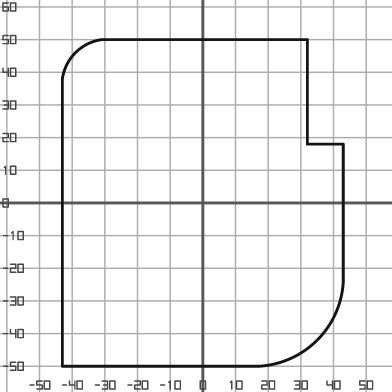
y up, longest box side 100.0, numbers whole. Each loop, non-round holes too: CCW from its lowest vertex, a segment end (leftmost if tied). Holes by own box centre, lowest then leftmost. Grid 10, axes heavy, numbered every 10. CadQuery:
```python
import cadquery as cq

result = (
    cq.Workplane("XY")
    .moveTo(-43.0, -50.0)
    .lineTo(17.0, -50.0)
    .threePointArc((35.0, -42.0), (43.0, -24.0))
    .lineTo(43.0, 18.0)
    .lineTo(32.0, 18.0)
    .lineTo(32.0, 50.0)
    .lineTo(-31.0, 50.0)
    .threePointArc((-39.0, 46.0), (-43.0, 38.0))
    .close()
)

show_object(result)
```